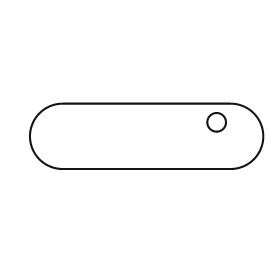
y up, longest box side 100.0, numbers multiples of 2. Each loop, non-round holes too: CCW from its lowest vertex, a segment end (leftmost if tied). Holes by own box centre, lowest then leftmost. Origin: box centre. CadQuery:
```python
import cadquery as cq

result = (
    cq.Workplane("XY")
    .moveTo(-36.0, -14.0)
    .lineTo(36.0, -14.0)
    .threePointArc((50.0, 0.0), (36.0, 14.0))
    .lineTo(-36.0, 14.0)
    .threePointArc((-50.0, 0.0), (-36.0, -14.0))
    .close()
    .moveTo(30.0, 6.0)
    .circle(4.0)
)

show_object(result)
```